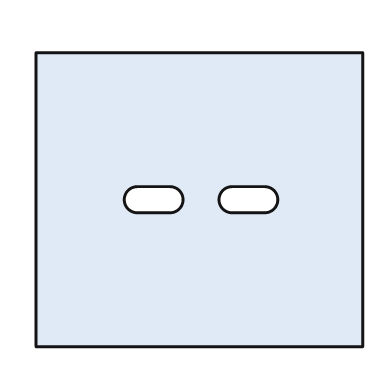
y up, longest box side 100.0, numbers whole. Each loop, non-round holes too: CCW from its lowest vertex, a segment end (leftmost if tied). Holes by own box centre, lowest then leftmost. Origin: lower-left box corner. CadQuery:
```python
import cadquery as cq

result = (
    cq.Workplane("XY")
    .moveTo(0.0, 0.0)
    .lineTo(100.0, 0.0)
    .lineTo(100.0, 90.0)
    .lineTo(0.0, 90.0)
    .close()
    .moveTo(31.0, 41.0)
    .lineTo(41.0, 41.0)
    .threePointArc((45.0, 45.0), (41.0, 49.0))
    .lineTo(31.0, 49.0)
    .threePointArc((27.0, 45.0), (31.0, 41.0))
    .close()
    .moveTo(60.0, 41.0)
    .lineTo(70.0, 41.0)
    .threePointArc((74.0, 45.0), (70.0, 49.0))
    .lineTo(60.0, 49.0)
    .threePointArc((56.0, 45.0), (60.0, 41.0))
    .close()
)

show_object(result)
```